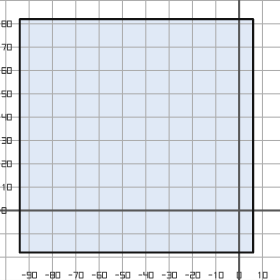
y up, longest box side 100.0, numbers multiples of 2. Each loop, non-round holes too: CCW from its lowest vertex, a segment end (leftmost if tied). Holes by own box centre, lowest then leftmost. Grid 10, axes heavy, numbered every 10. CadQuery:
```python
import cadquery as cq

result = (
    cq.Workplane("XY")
    .moveTo(-94.0, -18.0)
    .lineTo(6.0, -18.0)
    .lineTo(6.0, 82.0)
    .lineTo(-94.0, 82.0)
    .close()
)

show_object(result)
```